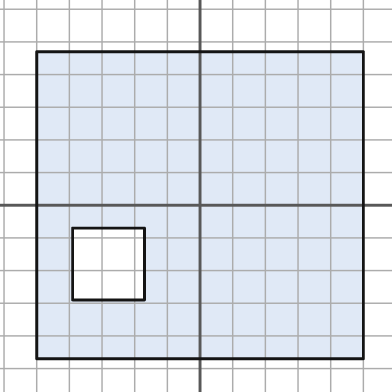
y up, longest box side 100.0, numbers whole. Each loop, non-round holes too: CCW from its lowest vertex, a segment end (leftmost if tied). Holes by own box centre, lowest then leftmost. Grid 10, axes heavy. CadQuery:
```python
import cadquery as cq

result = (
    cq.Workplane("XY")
    .moveTo(-50.0, -47.0)
    .lineTo(50.0, -47.0)
    .lineTo(50.0, 47.0)
    .lineTo(-50.0, 47.0)
    .close()
    .moveTo(-39.0, -29.0)
    .lineTo(-17.0, -29.0)
    .lineTo(-17.0, -7.0)
    .lineTo(-39.0, -7.0)
    .close()
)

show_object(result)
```